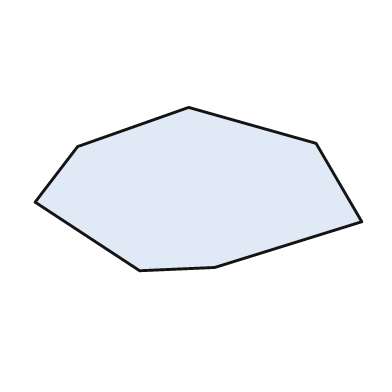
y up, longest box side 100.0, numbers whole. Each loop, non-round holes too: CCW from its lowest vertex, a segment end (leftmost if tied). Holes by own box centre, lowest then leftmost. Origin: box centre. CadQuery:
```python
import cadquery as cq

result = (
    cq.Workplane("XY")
    .moveTo(-18.0, -25.0)
    .lineTo(5.0, -24.0)
    .lineTo(50.0, -10.0)
    .lineTo(36.0, 14.0)
    .lineTo(-3.0, 25.0)
    .lineTo(-37.0, 13.0)
    .lineTo(-50.0, -4.0)
    .close()
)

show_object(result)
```